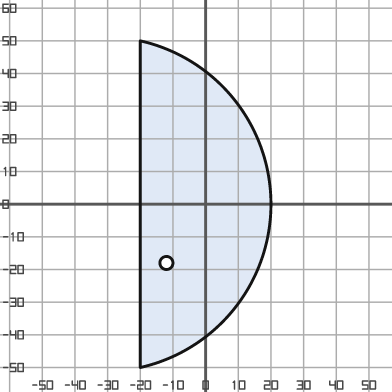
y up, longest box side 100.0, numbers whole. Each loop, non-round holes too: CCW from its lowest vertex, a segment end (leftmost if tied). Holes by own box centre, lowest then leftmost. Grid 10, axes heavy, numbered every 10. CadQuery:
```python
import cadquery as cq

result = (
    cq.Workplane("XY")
    .moveTo(-20.0, -50.0)
    .threePointArc((20.0, 0.0), (-20.0, 50.0))
    .close()
    .moveTo(-12.0, -18.0)
    .circle(2.0)
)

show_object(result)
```